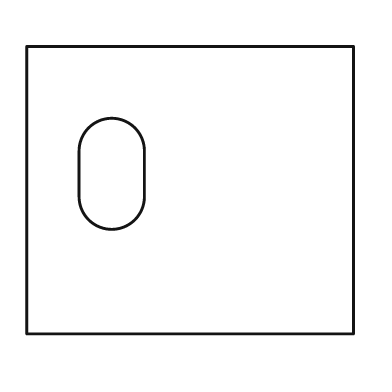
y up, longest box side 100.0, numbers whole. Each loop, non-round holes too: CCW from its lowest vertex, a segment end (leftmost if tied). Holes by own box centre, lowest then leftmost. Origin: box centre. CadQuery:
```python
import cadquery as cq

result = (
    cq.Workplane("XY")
    .moveTo(-50.0, -44.0)
    .lineTo(50.0, -44.0)
    .lineTo(50.0, 44.0)
    .lineTo(-50.0, 44.0)
    .close()
    .moveTo(-34.0, -2.0)
    .threePointArc((-24.0, -12.0), (-14.0, -2.0))
    .lineTo(-14.0, 12.0)
    .threePointArc((-24.0, 22.0), (-34.0, 12.0))
    .close()
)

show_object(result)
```